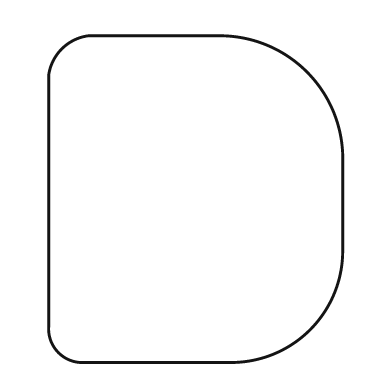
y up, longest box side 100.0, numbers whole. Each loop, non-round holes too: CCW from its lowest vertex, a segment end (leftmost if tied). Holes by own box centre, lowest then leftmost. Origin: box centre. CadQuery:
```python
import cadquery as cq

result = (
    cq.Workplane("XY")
    .moveTo(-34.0, -50.0)
    .lineTo(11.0, -50.0)
    .threePointArc((35.0, -40.0), (45.0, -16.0))
    .lineTo(45.0, 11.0)
    .threePointArc((34.0, 39.0), (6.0, 50.0))
    .lineTo(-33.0, 50.0)
    .threePointArc((-41.0, 46.0), (-45.0, 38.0))
    .lineTo(-45.0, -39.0)
    .threePointArc((-42.0, -47.0), (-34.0, -50.0))
    .close()
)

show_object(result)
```